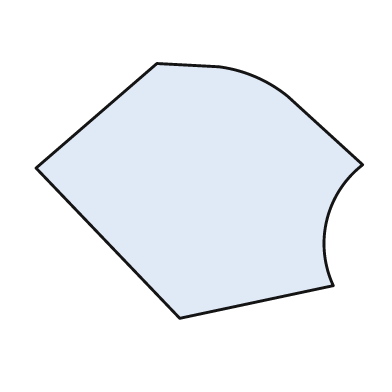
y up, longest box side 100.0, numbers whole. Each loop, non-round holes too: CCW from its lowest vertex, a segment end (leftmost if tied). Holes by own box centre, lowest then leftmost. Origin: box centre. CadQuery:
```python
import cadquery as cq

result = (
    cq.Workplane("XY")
    .moveTo(-6.0, -39.0)
    .lineTo(41.0, -29.0)
    .threePointArc((39.0, -9.0), (50.0, 8.0))
    .lineTo(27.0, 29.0)
    .threePointArc((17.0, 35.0), (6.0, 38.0))
    .lineTo(-13.0, 39.0)
    .lineTo(-50.0, 7.0)
    .close()
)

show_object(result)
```